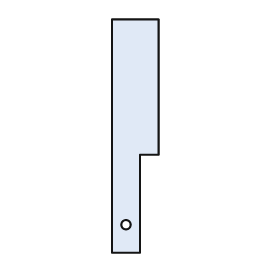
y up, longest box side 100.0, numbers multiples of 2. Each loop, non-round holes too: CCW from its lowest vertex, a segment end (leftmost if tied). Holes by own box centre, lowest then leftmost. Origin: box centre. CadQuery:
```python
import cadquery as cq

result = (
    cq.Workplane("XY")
    .moveTo(-10.0, -50.0)
    .lineTo(2.0, -50.0)
    .lineTo(2.0, -8.0)
    .lineTo(10.0, -8.0)
    .lineTo(10.0, 50.0)
    .lineTo(-10.0, 50.0)
    .close()
    .moveTo(-4.0, -38.0)
    .circle(2.0)
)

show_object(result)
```